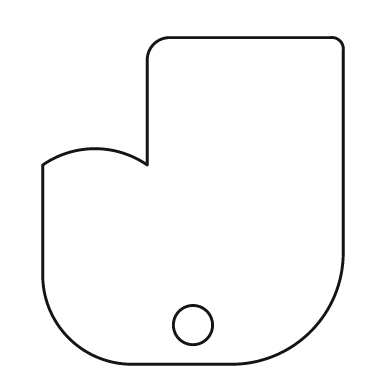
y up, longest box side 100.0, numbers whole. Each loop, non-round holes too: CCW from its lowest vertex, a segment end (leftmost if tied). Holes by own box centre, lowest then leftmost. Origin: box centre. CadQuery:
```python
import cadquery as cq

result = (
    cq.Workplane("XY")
    .moveTo(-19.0, -50.0)
    .lineTo(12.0, -50.0)
    .threePointArc((36.0, -40.0), (46.0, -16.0))
    .lineTo(46.0, 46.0)
    .threePointArc((45.0, 49.0), (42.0, 50.0))
    .lineTo(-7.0, 50.0)
    .threePointArc((-12.0, 48.0), (-14.0, 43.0))
    .lineTo(-14.0, 11.0)
    .threePointArc((-30.0, 16.0), (-46.0, 11.0))
    .lineTo(-46.0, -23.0)
    .threePointArc((-38.0, -42.0), (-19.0, -50.0))
    .close()
    .moveTo(0.0, -38.0)
    .circle(6.0)
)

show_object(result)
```